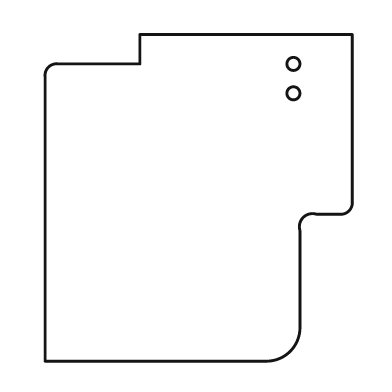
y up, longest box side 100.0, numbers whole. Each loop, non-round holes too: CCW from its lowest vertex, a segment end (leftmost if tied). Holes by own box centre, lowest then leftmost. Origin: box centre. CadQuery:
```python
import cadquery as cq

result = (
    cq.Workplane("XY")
    .moveTo(-47.0, -50.0)
    .lineTo(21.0, -50.0)
    .threePointArc((28.0, -47.0), (31.0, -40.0))
    .lineTo(31.0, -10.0)
    .threePointArc((32.0, -6.0), (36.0, -5.0))
    .lineTo(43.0, -5.0)
    .threePointArc((46.0, -4.0), (47.0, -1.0))
    .lineTo(47.0, 50.0)
    .lineTo(-18.0, 50.0)
    .lineTo(-18.0, 41.0)
    .lineTo(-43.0, 41.0)
    .threePointArc((-46.0, 40.0), (-47.0, 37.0))
    .close()
    .moveTo(29.0, 32.0)
    .circle(2.0)
    .moveTo(29.0, 41.0)
    .circle(2.0)
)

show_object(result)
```